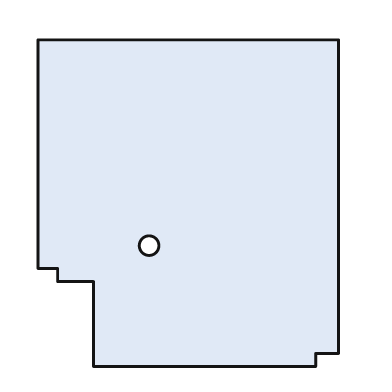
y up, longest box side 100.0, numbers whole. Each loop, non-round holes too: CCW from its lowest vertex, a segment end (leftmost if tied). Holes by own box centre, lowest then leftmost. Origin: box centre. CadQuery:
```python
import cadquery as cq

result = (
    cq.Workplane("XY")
    .moveTo(-29.0, -50.0)
    .lineTo(39.0, -50.0)
    .lineTo(39.0, -46.0)
    .lineTo(46.0, -46.0)
    .lineTo(46.0, 50.0)
    .lineTo(-46.0, 50.0)
    .lineTo(-46.0, -20.0)
    .lineTo(-40.0, -20.0)
    .lineTo(-40.0, -24.0)
    .lineTo(-29.0, -24.0)
    .close()
    .moveTo(-12.0, -13.0)
    .circle(3.0)
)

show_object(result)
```